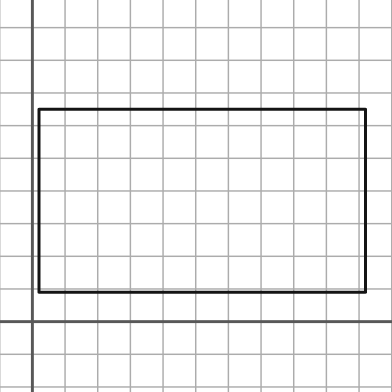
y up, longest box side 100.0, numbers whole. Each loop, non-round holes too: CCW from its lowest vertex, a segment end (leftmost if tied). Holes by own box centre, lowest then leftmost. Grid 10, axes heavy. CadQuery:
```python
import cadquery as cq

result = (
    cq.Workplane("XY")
    .moveTo(2.0, 9.0)
    .lineTo(102.0, 9.0)
    .lineTo(102.0, 65.0)
    .lineTo(2.0, 65.0)
    .close()
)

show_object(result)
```